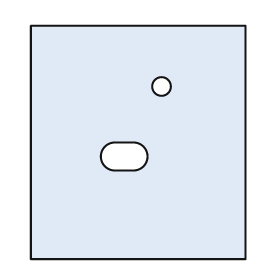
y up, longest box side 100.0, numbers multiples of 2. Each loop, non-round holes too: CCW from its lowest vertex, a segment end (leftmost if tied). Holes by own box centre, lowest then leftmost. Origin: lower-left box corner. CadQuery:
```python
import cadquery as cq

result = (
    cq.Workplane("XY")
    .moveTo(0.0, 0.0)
    .lineTo(92.0, 0.0)
    .lineTo(92.0, 100.0)
    .lineTo(0.0, 100.0)
    .close()
    .moveTo(36.0, 38.0)
    .lineTo(44.0, 38.0)
    .threePointArc((50.0, 44.0), (44.0, 50.0))
    .lineTo(36.0, 50.0)
    .threePointArc((30.0, 44.0), (36.0, 38.0))
    .close()
    .moveTo(56.0, 74.0)
    .circle(4.0)
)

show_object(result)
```